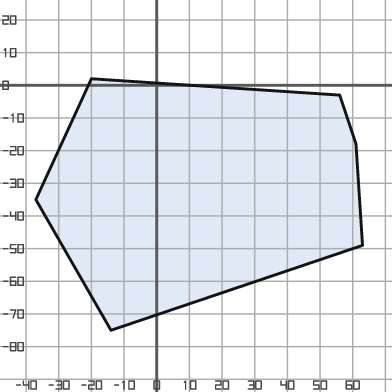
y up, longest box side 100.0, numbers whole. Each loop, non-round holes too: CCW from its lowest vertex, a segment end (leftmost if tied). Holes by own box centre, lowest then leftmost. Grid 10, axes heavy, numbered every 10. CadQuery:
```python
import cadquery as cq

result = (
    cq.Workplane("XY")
    .moveTo(-14.0, -75.0)
    .lineTo(63.0, -49.0)
    .lineTo(61.0, -18.0)
    .lineTo(56.0, -3.0)
    .lineTo(-20.0, 2.0)
    .lineTo(-37.0, -35.0)
    .close()
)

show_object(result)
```